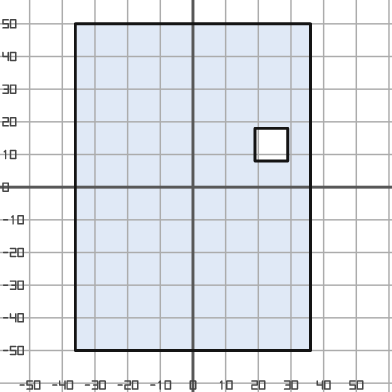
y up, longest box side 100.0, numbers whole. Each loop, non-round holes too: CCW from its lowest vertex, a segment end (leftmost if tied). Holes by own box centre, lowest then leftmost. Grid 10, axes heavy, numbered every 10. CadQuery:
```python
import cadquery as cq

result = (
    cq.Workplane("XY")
    .moveTo(-36.0, -50.0)
    .lineTo(36.0, -50.0)
    .lineTo(36.0, 50.0)
    .lineTo(-36.0, 50.0)
    .close()
    .moveTo(19.0, 8.0)
    .lineTo(29.0, 8.0)
    .lineTo(29.0, 18.0)
    .lineTo(19.0, 18.0)
    .close()
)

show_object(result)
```